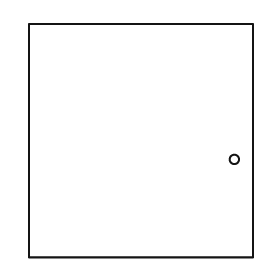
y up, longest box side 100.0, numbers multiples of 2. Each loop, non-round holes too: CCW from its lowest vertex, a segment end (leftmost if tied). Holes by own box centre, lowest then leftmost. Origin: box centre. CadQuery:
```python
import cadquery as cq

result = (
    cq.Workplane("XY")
    .moveTo(-48.0, -50.0)
    .lineTo(48.0, -50.0)
    .lineTo(48.0, 50.0)
    .lineTo(-48.0, 50.0)
    .close()
    .moveTo(40.0, -8.0)
    .circle(2.0)
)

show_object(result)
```